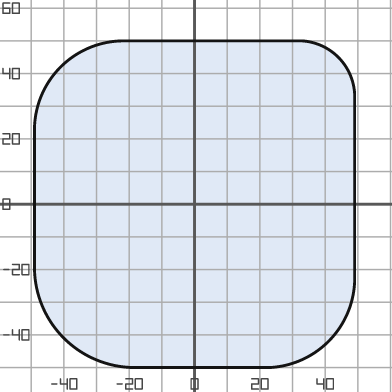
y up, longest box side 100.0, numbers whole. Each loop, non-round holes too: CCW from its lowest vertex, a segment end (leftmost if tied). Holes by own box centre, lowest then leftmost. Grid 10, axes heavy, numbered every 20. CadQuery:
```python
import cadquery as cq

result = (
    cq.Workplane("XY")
    .moveTo(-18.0, -50.0)
    .lineTo(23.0, -50.0)
    .threePointArc((41.0, -42.0), (49.0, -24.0))
    .lineTo(49.0, 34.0)
    .threePointArc((44.0, 45.0), (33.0, 50.0))
    .lineTo(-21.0, 50.0)
    .threePointArc((-41.0, 42.0), (-49.0, 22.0))
    .lineTo(-49.0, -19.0)
    .threePointArc((-40.0, -41.0), (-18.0, -50.0))
    .close()
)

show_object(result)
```